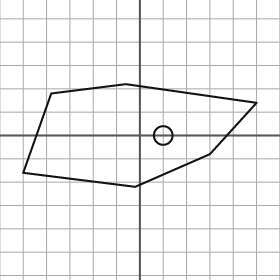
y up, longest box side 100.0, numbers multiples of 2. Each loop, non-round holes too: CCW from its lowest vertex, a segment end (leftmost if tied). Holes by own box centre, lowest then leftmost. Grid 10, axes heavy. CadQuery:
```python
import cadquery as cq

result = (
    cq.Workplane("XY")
    .moveTo(-2.0, -22.0)
    .lineTo(30.0, -8.0)
    .lineTo(50.0, 14.0)
    .lineTo(-6.0, 22.0)
    .lineTo(-38.0, 18.0)
    .lineTo(-50.0, -16.0)
    .close()
    .moveTo(10.0, 0.0)
    .circle(4.0)
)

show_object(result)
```